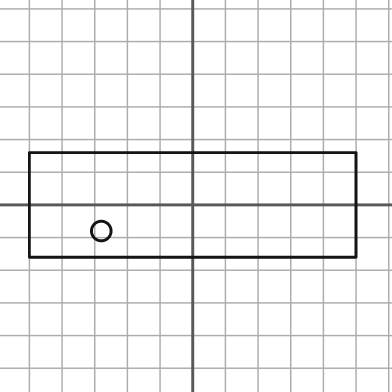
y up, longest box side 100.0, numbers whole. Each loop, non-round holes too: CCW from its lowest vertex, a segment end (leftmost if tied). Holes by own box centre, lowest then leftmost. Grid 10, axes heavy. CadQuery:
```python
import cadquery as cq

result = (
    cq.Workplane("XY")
    .moveTo(-50.0, -16.0)
    .lineTo(50.0, -16.0)
    .lineTo(50.0, 16.0)
    .lineTo(-50.0, 16.0)
    .close()
    .moveTo(-28.0, -8.0)
    .circle(3.0)
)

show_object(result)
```